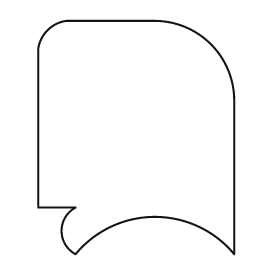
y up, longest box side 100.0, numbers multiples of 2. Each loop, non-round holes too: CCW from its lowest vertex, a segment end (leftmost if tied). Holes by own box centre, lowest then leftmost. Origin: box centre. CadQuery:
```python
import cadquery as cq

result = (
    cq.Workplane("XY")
    .moveTo(-26.0, -50.0)
    .threePointArc((8.0, -34.0), (42.0, -50.0))
    .lineTo(42.0, 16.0)
    .threePointArc((32.0, 40.0), (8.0, 50.0))
    .lineTo(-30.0, 50.0)
    .threePointArc((-38.0, 46.0), (-42.0, 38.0))
    .lineTo(-42.0, -30.0)
    .lineTo(-26.0, -30.0)
    .threePointArc((-32.0, -40.0), (-26.0, -50.0))
    .close()
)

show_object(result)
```